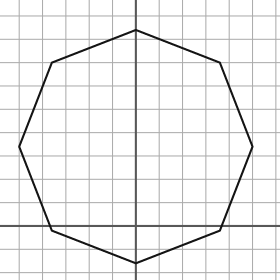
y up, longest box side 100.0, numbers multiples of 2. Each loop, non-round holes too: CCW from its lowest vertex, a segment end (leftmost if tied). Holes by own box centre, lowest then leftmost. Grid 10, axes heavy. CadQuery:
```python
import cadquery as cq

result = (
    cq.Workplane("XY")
    .moveTo(0.0, -16.0)
    .lineTo(36.0, -2.0)
    .lineTo(50.0, 34.0)
    .lineTo(36.0, 70.0)
    .lineTo(0.0, 84.0)
    .lineTo(-36.0, 70.0)
    .lineTo(-50.0, 34.0)
    .lineTo(-36.0, -2.0)
    .close()
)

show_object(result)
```